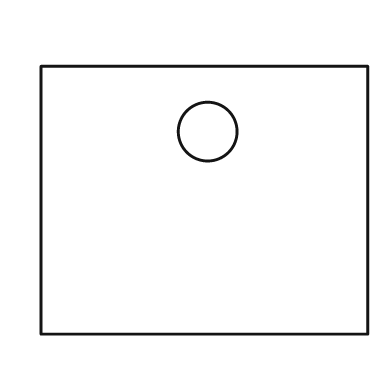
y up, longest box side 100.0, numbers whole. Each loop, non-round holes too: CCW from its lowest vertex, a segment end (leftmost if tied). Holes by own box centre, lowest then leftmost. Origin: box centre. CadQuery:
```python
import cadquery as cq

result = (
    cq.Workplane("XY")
    .moveTo(-50.0, -41.0)
    .lineTo(50.0, -41.0)
    .lineTo(50.0, 41.0)
    .lineTo(-50.0, 41.0)
    .close()
    .moveTo(1.0, 21.0)
    .circle(9.0)
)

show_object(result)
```